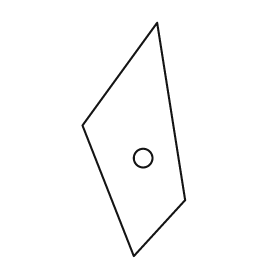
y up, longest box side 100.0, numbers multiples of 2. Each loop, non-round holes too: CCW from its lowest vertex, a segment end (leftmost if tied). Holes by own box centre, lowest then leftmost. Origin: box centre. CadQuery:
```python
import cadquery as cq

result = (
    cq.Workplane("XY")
    .moveTo(0.0, -50.0)
    .lineTo(22.0, -26.0)
    .lineTo(10.0, 50.0)
    .lineTo(-22.0, 6.0)
    .close()
    .moveTo(4.0, -8.0)
    .circle(4.0)
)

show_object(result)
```